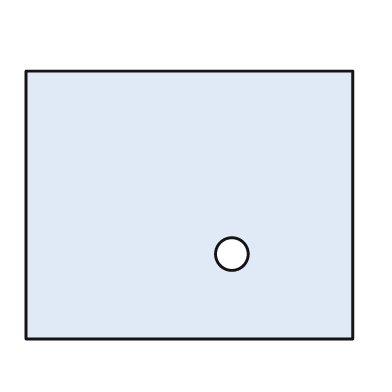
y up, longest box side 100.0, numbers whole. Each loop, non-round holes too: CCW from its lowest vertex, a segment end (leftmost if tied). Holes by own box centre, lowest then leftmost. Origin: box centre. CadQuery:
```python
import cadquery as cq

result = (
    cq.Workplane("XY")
    .moveTo(-50.0, -41.0)
    .lineTo(50.0, -41.0)
    .lineTo(50.0, 41.0)
    .lineTo(-50.0, 41.0)
    .close()
    .moveTo(13.0, -15.0)
    .circle(5.0)
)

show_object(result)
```